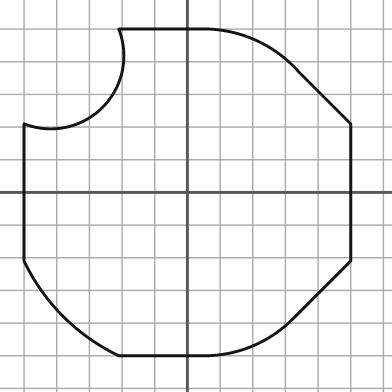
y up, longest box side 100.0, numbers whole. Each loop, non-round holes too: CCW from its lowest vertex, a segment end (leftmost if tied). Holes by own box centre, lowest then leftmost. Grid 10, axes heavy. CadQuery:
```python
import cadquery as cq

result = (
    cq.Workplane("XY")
    .moveTo(-21.0, -50.0)
    .lineTo(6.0, -50.0)
    .threePointArc((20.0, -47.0), (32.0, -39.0))
    .lineTo(50.0, -21.0)
    .lineTo(50.0, 21.0)
    .lineTo(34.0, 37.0)
    .threePointArc((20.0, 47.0), (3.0, 50.0))
    .lineTo(-21.0, 50.0)
    .threePointArc((-26.0, 26.0), (-50.0, 21.0))
    .lineTo(-50.0, -21.0)
    .threePointArc((-38.0, -38.0), (-21.0, -50.0))
    .close()
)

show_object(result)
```